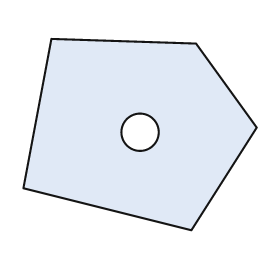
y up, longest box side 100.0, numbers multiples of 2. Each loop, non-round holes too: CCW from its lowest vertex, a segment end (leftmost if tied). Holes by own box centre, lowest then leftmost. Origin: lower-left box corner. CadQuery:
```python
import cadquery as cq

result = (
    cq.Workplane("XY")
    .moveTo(72.0, 0.0)
    .lineTo(100.0, 44.0)
    .lineTo(74.0, 80.0)
    .lineTo(12.0, 82.0)
    .lineTo(0.0, 18.0)
    .close()
    .moveTo(50.0, 42.0)
    .circle(8.0)
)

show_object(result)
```